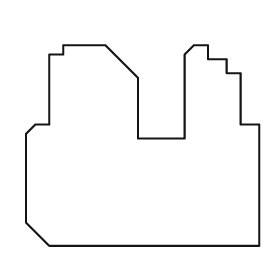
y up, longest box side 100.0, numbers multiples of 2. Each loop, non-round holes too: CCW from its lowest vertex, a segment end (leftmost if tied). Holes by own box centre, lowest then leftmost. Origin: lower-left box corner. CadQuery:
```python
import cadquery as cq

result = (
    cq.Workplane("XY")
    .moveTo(10.0, 0.0)
    .lineTo(100.0, 0.0)
    .lineTo(100.0, 52.0)
    .lineTo(92.0, 52.0)
    .lineTo(92.0, 74.0)
    .lineTo(86.0, 74.0)
    .lineTo(86.0, 80.0)
    .lineTo(78.0, 80.0)
    .lineTo(78.0, 86.0)
    .lineTo(72.0, 86.0)
    .lineTo(68.0, 82.0)
    .lineTo(68.0, 46.0)
    .lineTo(48.0, 46.0)
    .lineTo(48.0, 72.0)
    .lineTo(34.0, 86.0)
    .lineTo(16.0, 86.0)
    .lineTo(16.0, 82.0)
    .lineTo(10.0, 82.0)
    .lineTo(10.0, 52.0)
    .lineTo(4.0, 52.0)
    .lineTo(0.0, 48.0)
    .lineTo(0.0, 10.0)
    .close()
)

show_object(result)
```